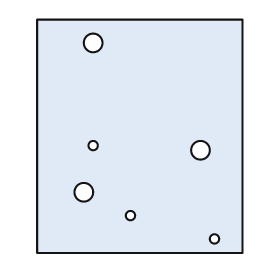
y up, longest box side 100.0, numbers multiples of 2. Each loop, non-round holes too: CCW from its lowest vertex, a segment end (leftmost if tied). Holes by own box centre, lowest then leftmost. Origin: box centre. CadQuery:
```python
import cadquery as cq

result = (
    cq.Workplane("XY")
    .moveTo(-44.0, -50.0)
    .lineTo(44.0, -50.0)
    .lineTo(44.0, 50.0)
    .lineTo(-44.0, 50.0)
    .close()
    .moveTo(32.0, -44.0)
    .circle(2.0)
    .moveTo(-4.0, -34.0)
    .circle(2.0)
    .moveTo(-24.0, -24.0)
    .circle(4.0)
    .moveTo(26.0, -6.0)
    .circle(4.0)
    .moveTo(-20.0, -4.0)
    .circle(2.0)
    .moveTo(-20.0, 40.0)
    .circle(4.0)
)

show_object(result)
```